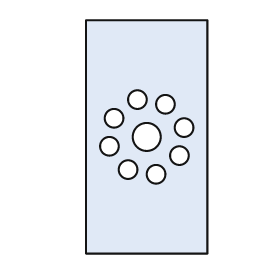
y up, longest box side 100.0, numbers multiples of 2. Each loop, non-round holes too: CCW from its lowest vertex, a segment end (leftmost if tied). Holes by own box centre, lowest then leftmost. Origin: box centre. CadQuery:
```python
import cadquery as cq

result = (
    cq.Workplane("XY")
    .moveTo(-26.0, -50.0)
    .lineTo(26.0, -50.0)
    .lineTo(26.0, 50.0)
    .lineTo(-26.0, 50.0)
    .close()
    .moveTo(4.0, -16.0)
    .circle(4.0)
    .moveTo(-8.0, -14.0)
    .circle(4.0)
    .moveTo(14.0, -8.0)
    .circle(4.0)
    .moveTo(-16.0, -4.0)
    .circle(4.0)
    .moveTo(0.0, 0.0)
    .circle(6.0)
    .moveTo(16.0, 4.0)
    .circle(4.0)
    .moveTo(-14.0, 8.0)
    .circle(4.0)
    .moveTo(8.0, 14.0)
    .circle(4.0)
    .moveTo(-4.0, 16.0)
    .circle(4.0)
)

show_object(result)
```